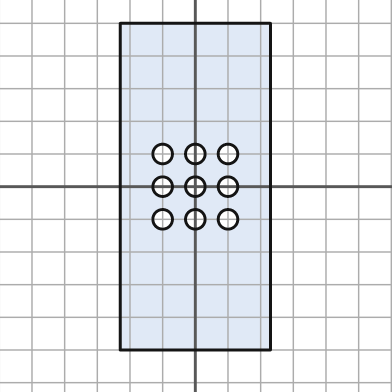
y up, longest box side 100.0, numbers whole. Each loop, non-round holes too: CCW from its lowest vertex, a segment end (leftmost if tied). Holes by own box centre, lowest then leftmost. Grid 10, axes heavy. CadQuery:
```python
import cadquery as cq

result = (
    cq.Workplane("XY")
    .moveTo(-23.0, -50.0)
    .lineTo(23.0, -50.0)
    .lineTo(23.0, 50.0)
    .lineTo(-23.0, 50.0)
    .close()
    .moveTo(-10.0, -10.0)
    .circle(3.0)
    .moveTo(0.0, -10.0)
    .circle(3.0)
    .moveTo(10.0, -10.0)
    .circle(3.0)
    .moveTo(-10.0, 0.0)
    .circle(3.0)
    .moveTo(0.0, 0.0)
    .circle(3.0)
    .moveTo(10.0, 0.0)
    .circle(3.0)
    .moveTo(-10.0, 10.0)
    .circle(3.0)
    .moveTo(0.0, 10.0)
    .circle(3.0)
    .moveTo(10.0, 10.0)
    .circle(3.0)
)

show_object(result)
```